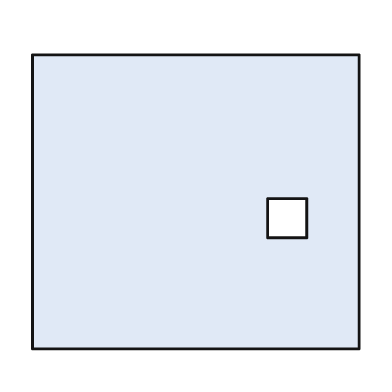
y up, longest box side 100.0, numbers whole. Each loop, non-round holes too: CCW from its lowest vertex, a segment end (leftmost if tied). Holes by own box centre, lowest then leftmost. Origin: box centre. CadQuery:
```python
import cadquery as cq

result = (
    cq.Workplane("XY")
    .moveTo(-50.0, -45.0)
    .lineTo(50.0, -45.0)
    .lineTo(50.0, 45.0)
    .lineTo(-50.0, 45.0)
    .close()
    .moveTo(22.0, -11.0)
    .lineTo(34.0, -11.0)
    .lineTo(34.0, 1.0)
    .lineTo(22.0, 1.0)
    .close()
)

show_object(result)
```